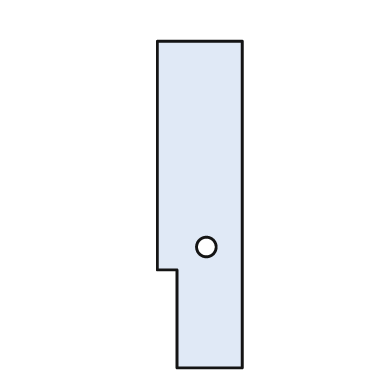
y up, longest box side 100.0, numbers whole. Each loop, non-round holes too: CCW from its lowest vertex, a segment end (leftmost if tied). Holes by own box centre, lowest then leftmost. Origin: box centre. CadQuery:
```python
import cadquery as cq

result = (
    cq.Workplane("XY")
    .moveTo(-7.0, -50.0)
    .lineTo(13.0, -50.0)
    .lineTo(13.0, 50.0)
    .lineTo(-13.0, 50.0)
    .lineTo(-13.0, -20.0)
    .lineTo(-7.0, -20.0)
    .close()
    .moveTo(2.0, -13.0)
    .circle(3.0)
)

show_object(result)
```